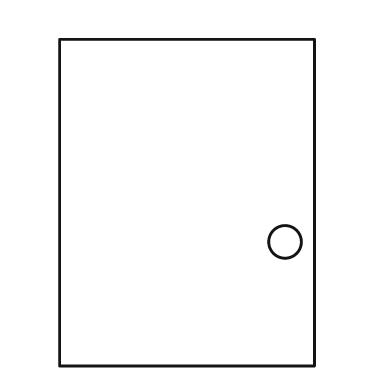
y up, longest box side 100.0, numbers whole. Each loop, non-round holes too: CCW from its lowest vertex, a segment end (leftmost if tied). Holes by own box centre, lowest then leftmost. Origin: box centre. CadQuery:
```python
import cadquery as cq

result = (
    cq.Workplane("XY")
    .moveTo(-39.0, -50.0)
    .lineTo(39.0, -50.0)
    .lineTo(39.0, 50.0)
    .lineTo(-39.0, 50.0)
    .close()
    .moveTo(30.0, -12.0)
    .circle(5.0)
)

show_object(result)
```